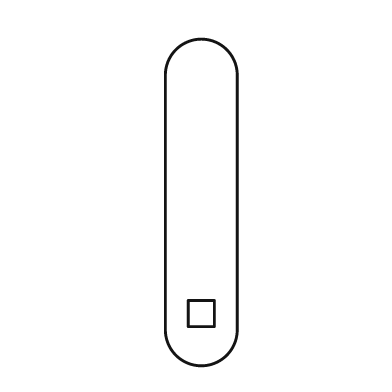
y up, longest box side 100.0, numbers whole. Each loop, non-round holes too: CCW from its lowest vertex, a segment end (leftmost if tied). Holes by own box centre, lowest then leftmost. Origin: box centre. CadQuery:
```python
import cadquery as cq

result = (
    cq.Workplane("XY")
    .moveTo(-11.0, -39.0)
    .threePointArc((0.0, -50.0), (11.0, -39.0))
    .lineTo(11.0, 39.0)
    .threePointArc((0.0, 50.0), (-11.0, 39.0))
    .close()
    .moveTo(-4.0, -38.0)
    .lineTo(4.0, -38.0)
    .lineTo(4.0, -30.0)
    .lineTo(-4.0, -30.0)
    .close()
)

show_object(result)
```